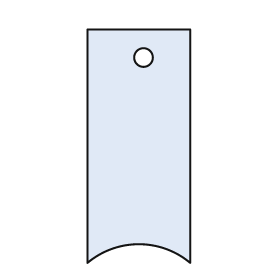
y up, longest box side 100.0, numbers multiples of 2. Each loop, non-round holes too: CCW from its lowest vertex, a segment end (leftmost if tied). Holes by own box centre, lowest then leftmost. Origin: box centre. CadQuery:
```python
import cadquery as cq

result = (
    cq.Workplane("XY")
    .moveTo(-22.0, -50.0)
    .threePointArc((0.0, -42.0), (22.0, -50.0))
    .lineTo(22.0, 50.0)
    .lineTo(-22.0, 50.0)
    .close()
    .moveTo(2.0, 38.0)
    .circle(4.0)
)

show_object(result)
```